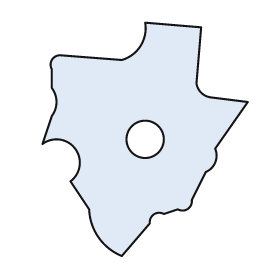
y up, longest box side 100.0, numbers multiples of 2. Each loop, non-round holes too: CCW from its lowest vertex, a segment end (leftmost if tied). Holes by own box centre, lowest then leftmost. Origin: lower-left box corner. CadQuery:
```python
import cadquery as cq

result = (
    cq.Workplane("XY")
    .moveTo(34.0, 0.0)
    .lineTo(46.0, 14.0)
    .threePointArc((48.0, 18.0), (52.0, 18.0))
    .lineTo(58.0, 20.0)
    .threePointArc((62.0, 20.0), (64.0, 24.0))
    .lineTo(70.0, 36.0)
    .threePointArc((74.0, 40.0), (74.0, 46.0))
    .lineTo(88.0, 66.0)
    .lineTo(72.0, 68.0)
    .threePointArc((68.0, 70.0), (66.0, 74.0))
    .lineTo(68.0, 98.0)
    .lineTo(44.0, 100.0)
    .threePointArc((42.0, 90.0), (34.0, 84.0))
    .lineTo(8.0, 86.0)
    .threePointArc((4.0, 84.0), (4.0, 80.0))
    .lineTo(4.0, 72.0)
    .threePointArc((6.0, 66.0), (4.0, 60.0))
    .lineTo(0.0, 48.0)
    .threePointArc((14.0, 46.0), (12.0, 32.0))
    .lineTo(20.0, 20.0)
    .threePointArc((24.0, 8.0), (34.0, 0.0))
    .close()
    .moveTo(44.0, 50.0)
    .circle(8.0)
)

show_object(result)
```